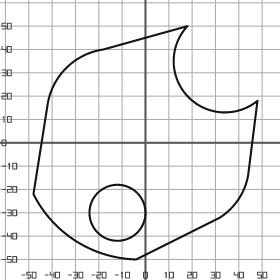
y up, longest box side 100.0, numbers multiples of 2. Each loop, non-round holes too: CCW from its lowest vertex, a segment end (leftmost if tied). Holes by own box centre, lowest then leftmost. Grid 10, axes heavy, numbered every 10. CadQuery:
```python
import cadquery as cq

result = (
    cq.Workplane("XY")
    .moveTo(-4.0, -50.0)
    .lineTo(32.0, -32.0)
    .threePointArc((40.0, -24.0), (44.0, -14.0))
    .lineTo(48.0, 18.0)
    .threePointArc((18.0, 20.0), (18.0, 50.0))
    .lineTo(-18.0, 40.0)
    .threePointArc((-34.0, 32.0), (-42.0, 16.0))
    .lineTo(-48.0, -22.0)
    .threePointArc((-30.0, -42.0), (-4.0, -50.0))
    .close()
    .moveTo(-12.0, -30.0)
    .circle(12.0)
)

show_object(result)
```